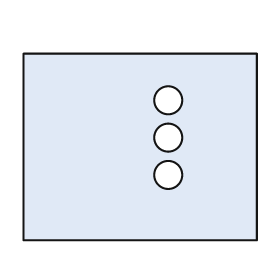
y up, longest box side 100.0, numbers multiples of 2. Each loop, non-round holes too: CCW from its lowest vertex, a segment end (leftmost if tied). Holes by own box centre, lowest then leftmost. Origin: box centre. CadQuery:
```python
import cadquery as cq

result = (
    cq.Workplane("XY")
    .moveTo(-50.0, -40.0)
    .lineTo(50.0, -40.0)
    .lineTo(50.0, 40.0)
    .lineTo(-50.0, 40.0)
    .close()
    .moveTo(12.0, -12.0)
    .circle(6.0)
    .moveTo(12.0, 4.0)
    .circle(6.0)
    .moveTo(12.0, 20.0)
    .circle(6.0)
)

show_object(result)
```